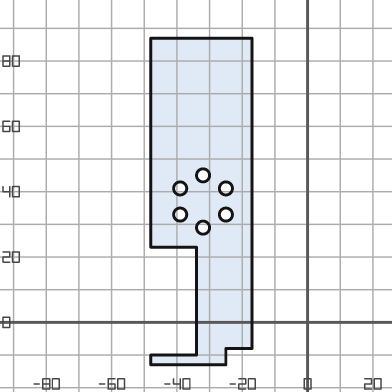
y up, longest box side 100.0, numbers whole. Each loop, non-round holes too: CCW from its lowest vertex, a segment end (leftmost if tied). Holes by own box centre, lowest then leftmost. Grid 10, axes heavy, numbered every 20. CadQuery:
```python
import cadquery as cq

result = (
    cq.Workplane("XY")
    .moveTo(-48.0, -13.0)
    .lineTo(-25.0, -13.0)
    .lineTo(-25.0, -8.0)
    .lineTo(-17.0, -8.0)
    .lineTo(-17.0, 87.0)
    .lineTo(-48.0, 87.0)
    .lineTo(-48.0, 23.0)
    .lineTo(-34.0, 23.0)
    .lineTo(-34.0, -10.0)
    .lineTo(-48.0, -10.0)
    .close()
    .moveTo(-32.0, 29.0)
    .circle(2.0)
    .moveTo(-39.0, 33.0)
    .circle(2.0)
    .moveTo(-25.0, 33.0)
    .circle(2.0)
    .moveTo(-39.0, 41.0)
    .circle(2.0)
    .moveTo(-25.0, 41.0)
    .circle(2.0)
    .moveTo(-32.0, 45.0)
    .circle(2.0)
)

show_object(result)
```